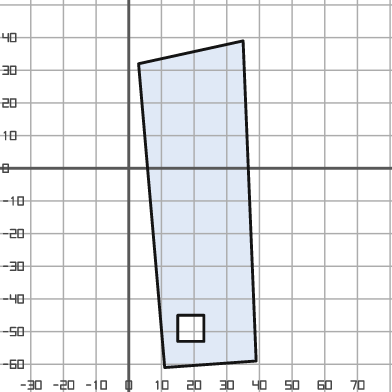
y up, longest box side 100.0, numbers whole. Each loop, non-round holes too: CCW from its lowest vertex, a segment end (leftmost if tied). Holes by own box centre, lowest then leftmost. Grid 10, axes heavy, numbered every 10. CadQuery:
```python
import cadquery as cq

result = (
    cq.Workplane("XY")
    .moveTo(11.0, -61.0)
    .lineTo(39.0, -59.0)
    .lineTo(35.0, 39.0)
    .lineTo(3.0, 32.0)
    .close()
    .moveTo(15.0, -53.0)
    .lineTo(23.0, -53.0)
    .lineTo(23.0, -45.0)
    .lineTo(15.0, -45.0)
    .close()
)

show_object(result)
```